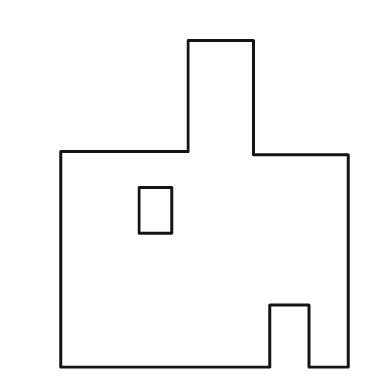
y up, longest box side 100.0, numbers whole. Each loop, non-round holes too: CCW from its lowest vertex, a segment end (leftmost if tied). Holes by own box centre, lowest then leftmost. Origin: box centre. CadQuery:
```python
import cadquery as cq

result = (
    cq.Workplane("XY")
    .moveTo(-44.0, -50.0)
    .lineTo(20.0, -50.0)
    .lineTo(20.0, -31.0)
    .lineTo(32.0, -31.0)
    .lineTo(32.0, -50.0)
    .lineTo(44.0, -50.0)
    .lineTo(44.0, 15.0)
    .lineTo(15.0, 15.0)
    .lineTo(15.0, 50.0)
    .lineTo(-5.0, 50.0)
    .lineTo(-5.0, 16.0)
    .lineTo(-44.0, 16.0)
    .close()
    .moveTo(-20.0, -9.0)
    .lineTo(-10.0, -9.0)
    .lineTo(-10.0, 5.0)
    .lineTo(-20.0, 5.0)
    .close()
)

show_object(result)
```